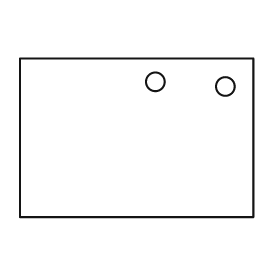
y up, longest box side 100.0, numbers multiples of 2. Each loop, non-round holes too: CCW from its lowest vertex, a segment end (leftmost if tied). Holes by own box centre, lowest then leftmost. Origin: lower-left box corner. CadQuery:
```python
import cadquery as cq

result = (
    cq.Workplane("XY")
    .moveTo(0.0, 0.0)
    .lineTo(100.0, 0.0)
    .lineTo(100.0, 68.0)
    .lineTo(0.0, 68.0)
    .close()
    .moveTo(88.0, 56.0)
    .circle(4.0)
    .moveTo(58.0, 58.0)
    .circle(4.0)
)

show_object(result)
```